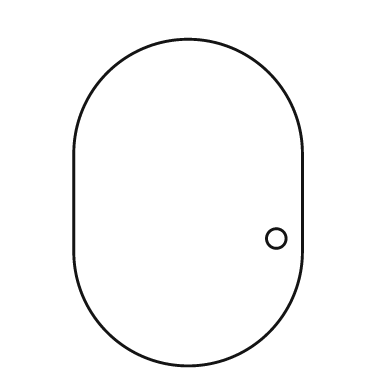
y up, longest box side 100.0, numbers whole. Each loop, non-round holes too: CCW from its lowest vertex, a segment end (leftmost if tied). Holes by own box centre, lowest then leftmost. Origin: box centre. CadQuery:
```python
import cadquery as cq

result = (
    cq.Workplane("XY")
    .moveTo(-35.0, -15.0)
    .threePointArc((0.0, -50.0), (35.0, -15.0))
    .lineTo(35.0, 15.0)
    .threePointArc((0.0, 50.0), (-35.0, 15.0))
    .close()
    .moveTo(27.0, -11.0)
    .circle(3.0)
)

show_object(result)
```